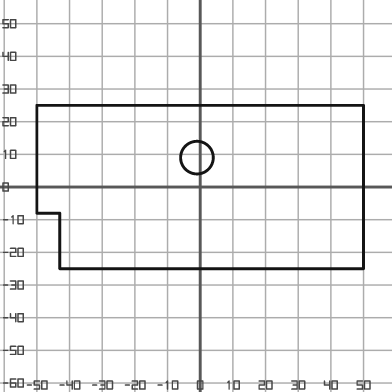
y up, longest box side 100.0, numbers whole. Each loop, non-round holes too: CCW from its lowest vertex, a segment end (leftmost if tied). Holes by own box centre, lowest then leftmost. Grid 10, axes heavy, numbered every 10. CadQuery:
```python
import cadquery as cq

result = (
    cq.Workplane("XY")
    .moveTo(-43.0, -25.0)
    .lineTo(50.0, -25.0)
    .lineTo(50.0, 25.0)
    .lineTo(-50.0, 25.0)
    .lineTo(-50.0, -8.0)
    .lineTo(-43.0, -8.0)
    .close()
    .moveTo(-1.0, 9.0)
    .circle(5.0)
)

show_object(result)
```